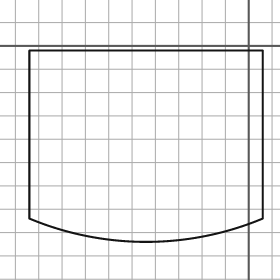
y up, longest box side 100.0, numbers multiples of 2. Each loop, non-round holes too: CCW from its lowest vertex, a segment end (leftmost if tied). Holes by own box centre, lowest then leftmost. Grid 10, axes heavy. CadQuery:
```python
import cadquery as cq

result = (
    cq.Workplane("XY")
    .moveTo(-94.0, -74.0)
    .threePointArc((-44.0, -84.0), (6.0, -74.0))
    .lineTo(6.0, -2.0)
    .lineTo(-94.0, -2.0)
    .close()
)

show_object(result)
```